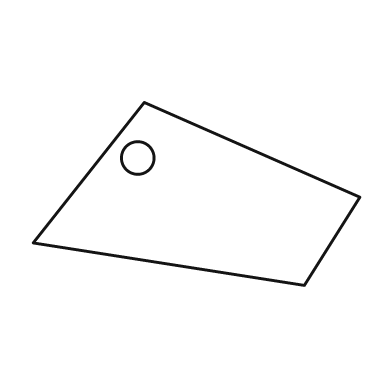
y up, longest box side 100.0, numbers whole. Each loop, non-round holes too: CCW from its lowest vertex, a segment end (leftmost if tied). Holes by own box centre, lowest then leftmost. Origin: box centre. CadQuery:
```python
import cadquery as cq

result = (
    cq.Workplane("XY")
    .moveTo(33.0, -28.0)
    .lineTo(50.0, -1.0)
    .lineTo(-16.0, 28.0)
    .lineTo(-50.0, -15.0)
    .close()
    .moveTo(-18.0, 11.0)
    .circle(5.0)
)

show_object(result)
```